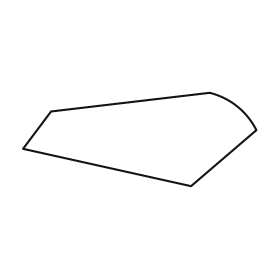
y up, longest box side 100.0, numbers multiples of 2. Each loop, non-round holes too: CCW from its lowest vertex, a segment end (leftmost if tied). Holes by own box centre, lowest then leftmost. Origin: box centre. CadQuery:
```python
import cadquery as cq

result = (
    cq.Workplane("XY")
    .moveTo(22.0, -20.0)
    .lineTo(50.0, 4.0)
    .threePointArc((42.0, 14.0), (30.0, 20.0))
    .lineTo(-38.0, 12.0)
    .lineTo(-50.0, -4.0)
    .close()
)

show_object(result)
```